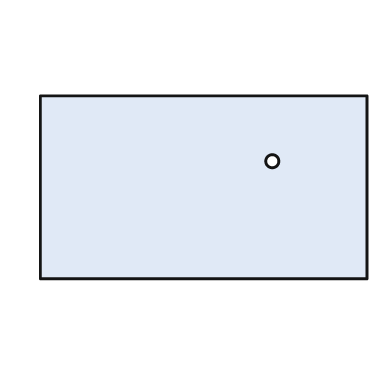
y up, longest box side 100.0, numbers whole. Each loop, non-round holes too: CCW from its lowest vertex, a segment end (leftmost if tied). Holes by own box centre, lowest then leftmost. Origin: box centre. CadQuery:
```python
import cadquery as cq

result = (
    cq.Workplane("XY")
    .moveTo(-50.0, -28.0)
    .lineTo(50.0, -28.0)
    .lineTo(50.0, 28.0)
    .lineTo(-50.0, 28.0)
    .close()
    .moveTo(21.0, 8.0)
    .circle(2.0)
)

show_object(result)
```